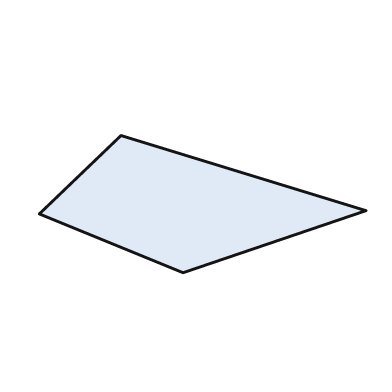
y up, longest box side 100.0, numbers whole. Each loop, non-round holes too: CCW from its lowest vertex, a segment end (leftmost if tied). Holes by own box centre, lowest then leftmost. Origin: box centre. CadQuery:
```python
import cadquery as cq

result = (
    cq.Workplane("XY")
    .moveTo(-6.0, -21.0)
    .lineTo(50.0, -2.0)
    .lineTo(-25.0, 21.0)
    .lineTo(-50.0, -3.0)
    .close()
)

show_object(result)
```